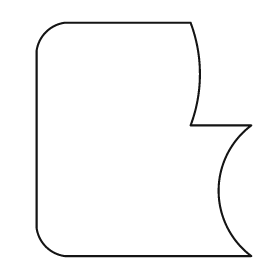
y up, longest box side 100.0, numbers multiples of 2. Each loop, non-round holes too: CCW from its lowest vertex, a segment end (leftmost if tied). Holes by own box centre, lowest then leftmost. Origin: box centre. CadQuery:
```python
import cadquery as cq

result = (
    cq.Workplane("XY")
    .moveTo(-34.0, -50.0)
    .lineTo(46.0, -50.0)
    .threePointArc((32.0, -22.0), (46.0, 6.0))
    .lineTo(20.0, 6.0)
    .threePointArc((24.0, 28.0), (20.0, 50.0))
    .lineTo(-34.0, 50.0)
    .threePointArc((-42.0, 46.0), (-46.0, 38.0))
    .lineTo(-46.0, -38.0)
    .threePointArc((-42.0, -46.0), (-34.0, -50.0))
    .close()
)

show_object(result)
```